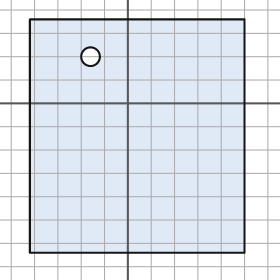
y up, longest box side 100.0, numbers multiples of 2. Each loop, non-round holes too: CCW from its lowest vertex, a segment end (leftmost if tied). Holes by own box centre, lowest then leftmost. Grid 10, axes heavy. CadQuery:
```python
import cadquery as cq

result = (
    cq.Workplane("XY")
    .moveTo(-42.0, -64.0)
    .lineTo(50.0, -64.0)
    .lineTo(50.0, 36.0)
    .lineTo(-42.0, 36.0)
    .close()
    .moveTo(-16.0, 20.0)
    .circle(4.0)
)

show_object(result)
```